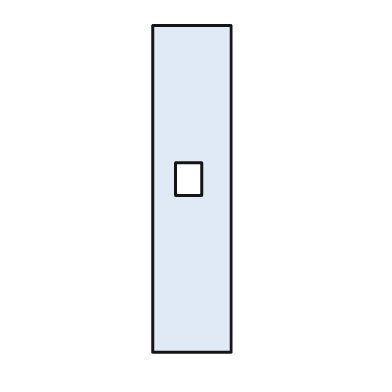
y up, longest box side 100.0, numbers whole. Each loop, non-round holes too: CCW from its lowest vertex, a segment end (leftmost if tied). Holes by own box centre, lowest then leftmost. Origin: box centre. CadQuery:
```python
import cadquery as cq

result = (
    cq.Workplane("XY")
    .moveTo(-12.0, -50.0)
    .lineTo(12.0, -50.0)
    .lineTo(12.0, 50.0)
    .lineTo(-12.0, 50.0)
    .close()
    .moveTo(-5.0, -2.0)
    .lineTo(3.0, -2.0)
    .lineTo(3.0, 8.0)
    .lineTo(-5.0, 8.0)
    .close()
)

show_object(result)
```